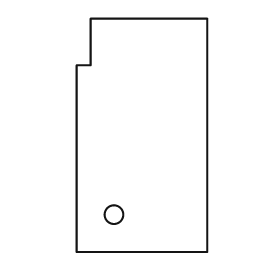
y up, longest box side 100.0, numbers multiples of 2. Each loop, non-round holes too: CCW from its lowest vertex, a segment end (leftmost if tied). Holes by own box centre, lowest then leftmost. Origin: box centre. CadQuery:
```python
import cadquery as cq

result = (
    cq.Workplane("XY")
    .moveTo(-28.0, -50.0)
    .lineTo(28.0, -50.0)
    .lineTo(28.0, 50.0)
    .lineTo(-22.0, 50.0)
    .lineTo(-22.0, 30.0)
    .lineTo(-28.0, 30.0)
    .close()
    .moveTo(-12.0, -34.0)
    .circle(4.0)
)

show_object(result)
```